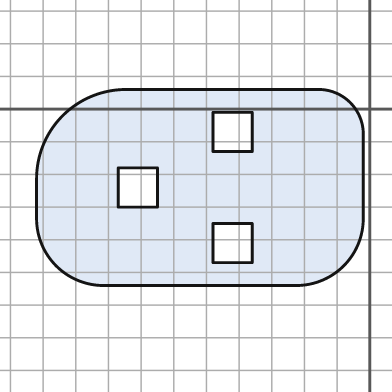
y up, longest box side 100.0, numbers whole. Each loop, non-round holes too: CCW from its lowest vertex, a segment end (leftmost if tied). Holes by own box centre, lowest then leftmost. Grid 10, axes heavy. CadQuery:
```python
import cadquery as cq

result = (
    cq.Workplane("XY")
    .moveTo(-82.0, -54.0)
    .lineTo(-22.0, -54.0)
    .threePointArc((-8.0, -48.0), (-2.0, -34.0))
    .lineTo(-2.0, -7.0)
    .threePointArc((-6.0, 2.0), (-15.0, 6.0))
    .lineTo(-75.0, 6.0)
    .threePointArc((-94.0, -2.0), (-102.0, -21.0))
    .lineTo(-102.0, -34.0)
    .threePointArc((-96.0, -48.0), (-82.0, -54.0))
    .close()
    .moveTo(-48.0, -47.0)
    .lineTo(-36.0, -47.0)
    .lineTo(-36.0, -35.0)
    .lineTo(-48.0, -35.0)
    .close()
    .moveTo(-77.0, -30.0)
    .lineTo(-65.0, -30.0)
    .lineTo(-65.0, -18.0)
    .lineTo(-77.0, -18.0)
    .close()
    .moveTo(-48.0, -13.0)
    .lineTo(-36.0, -13.0)
    .lineTo(-36.0, -1.0)
    .lineTo(-48.0, -1.0)
    .close()
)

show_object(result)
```